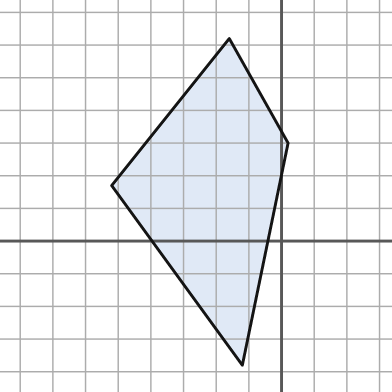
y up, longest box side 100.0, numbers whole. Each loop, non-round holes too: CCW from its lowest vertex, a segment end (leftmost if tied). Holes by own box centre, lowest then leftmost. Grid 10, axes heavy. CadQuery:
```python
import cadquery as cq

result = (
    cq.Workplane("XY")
    .moveTo(-12.0, -38.0)
    .lineTo(2.0, 30.0)
    .lineTo(-16.0, 62.0)
    .lineTo(-52.0, 17.0)
    .close()
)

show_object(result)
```